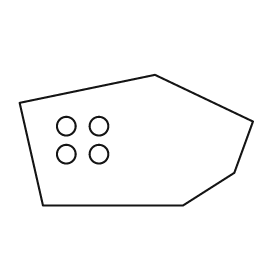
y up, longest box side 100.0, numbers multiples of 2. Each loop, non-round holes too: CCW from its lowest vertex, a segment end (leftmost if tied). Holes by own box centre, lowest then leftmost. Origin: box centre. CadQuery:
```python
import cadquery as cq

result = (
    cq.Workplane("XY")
    .moveTo(-40.0, -28.0)
    .lineTo(20.0, -28.0)
    .lineTo(42.0, -14.0)
    .lineTo(50.0, 8.0)
    .lineTo(8.0, 28.0)
    .lineTo(-50.0, 16.0)
    .close()
    .moveTo(-30.0, -6.0)
    .circle(4.0)
    .moveTo(-16.0, -6.0)
    .circle(4.0)
    .moveTo(-30.0, 6.0)
    .circle(4.0)
    .moveTo(-16.0, 6.0)
    .circle(4.0)
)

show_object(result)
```